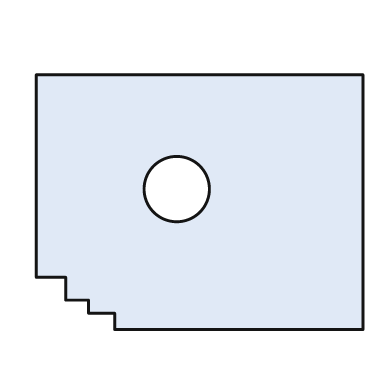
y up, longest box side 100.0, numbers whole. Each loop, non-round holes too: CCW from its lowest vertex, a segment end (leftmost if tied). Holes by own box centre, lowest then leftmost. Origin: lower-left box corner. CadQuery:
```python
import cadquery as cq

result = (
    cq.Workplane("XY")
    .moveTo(24.0, 0.0)
    .lineTo(100.0, 0.0)
    .lineTo(100.0, 78.0)
    .lineTo(0.0, 78.0)
    .lineTo(0.0, 16.0)
    .lineTo(9.0, 16.0)
    .lineTo(9.0, 9.0)
    .lineTo(16.0, 9.0)
    .lineTo(16.0, 5.0)
    .lineTo(24.0, 5.0)
    .close()
    .moveTo(43.0, 43.0)
    .circle(10.0)
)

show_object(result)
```